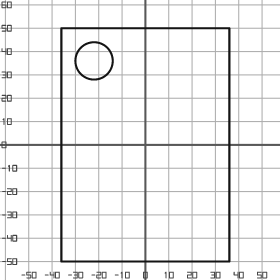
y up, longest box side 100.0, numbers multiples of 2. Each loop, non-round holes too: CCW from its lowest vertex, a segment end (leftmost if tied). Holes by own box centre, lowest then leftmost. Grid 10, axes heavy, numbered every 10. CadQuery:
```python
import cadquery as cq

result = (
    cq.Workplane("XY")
    .moveTo(-36.0, -50.0)
    .lineTo(36.0, -50.0)
    .lineTo(36.0, 50.0)
    .lineTo(-36.0, 50.0)
    .close()
    .moveTo(-22.0, 36.0)
    .circle(8.0)
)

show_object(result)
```